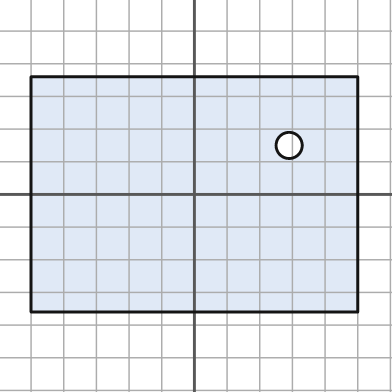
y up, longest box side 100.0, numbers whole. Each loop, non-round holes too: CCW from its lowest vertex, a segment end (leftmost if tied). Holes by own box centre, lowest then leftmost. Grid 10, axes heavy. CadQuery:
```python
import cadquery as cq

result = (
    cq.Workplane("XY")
    .moveTo(-50.0, -36.0)
    .lineTo(50.0, -36.0)
    .lineTo(50.0, 36.0)
    .lineTo(-50.0, 36.0)
    .close()
    .moveTo(29.0, 15.0)
    .circle(4.0)
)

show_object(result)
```